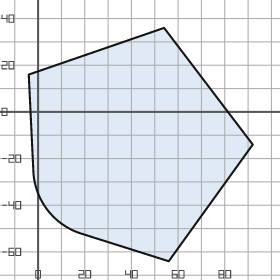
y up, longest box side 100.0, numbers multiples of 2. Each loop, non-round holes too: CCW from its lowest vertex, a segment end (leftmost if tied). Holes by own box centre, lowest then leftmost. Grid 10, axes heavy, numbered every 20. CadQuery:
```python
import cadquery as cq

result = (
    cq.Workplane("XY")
    .moveTo(56.0, -64.0)
    .lineTo(92.0, -14.0)
    .lineTo(54.0, 36.0)
    .lineTo(-4.0, 16.0)
    .lineTo(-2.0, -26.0)
    .threePointArc((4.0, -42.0), (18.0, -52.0))
    .close()
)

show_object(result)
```